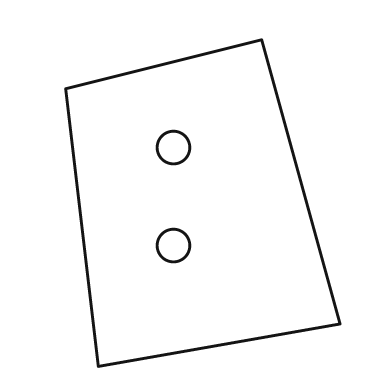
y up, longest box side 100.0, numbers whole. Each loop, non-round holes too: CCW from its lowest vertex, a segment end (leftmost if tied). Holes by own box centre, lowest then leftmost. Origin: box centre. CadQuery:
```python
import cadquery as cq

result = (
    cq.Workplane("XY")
    .moveTo(-32.0, -50.0)
    .lineTo(42.0, -37.0)
    .lineTo(18.0, 50.0)
    .lineTo(-42.0, 35.0)
    .close()
    .moveTo(-9.0, -13.0)
    .circle(5.0)
    .moveTo(-9.0, 17.0)
    .circle(5.0)
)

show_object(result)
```